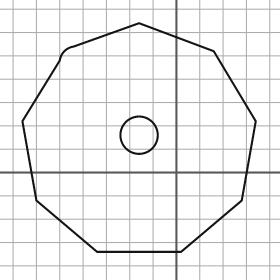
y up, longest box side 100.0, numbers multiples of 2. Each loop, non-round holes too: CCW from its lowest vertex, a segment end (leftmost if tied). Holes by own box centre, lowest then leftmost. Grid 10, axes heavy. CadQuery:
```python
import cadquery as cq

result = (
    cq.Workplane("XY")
    .moveTo(-34.0, -34.0)
    .lineTo(2.0, -34.0)
    .lineTo(28.0, -12.0)
    .lineTo(34.0, 22.0)
    .lineTo(16.0, 52.0)
    .lineTo(-16.0, 64.0)
    .lineTo(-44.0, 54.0)
    .threePointArc((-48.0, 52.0), (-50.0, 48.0))
    .lineTo(-66.0, 22.0)
    .lineTo(-60.0, -12.0)
    .close()
    .moveTo(-16.0, 16.0)
    .circle(8.0)
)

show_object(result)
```